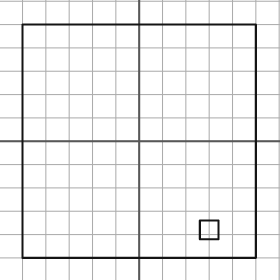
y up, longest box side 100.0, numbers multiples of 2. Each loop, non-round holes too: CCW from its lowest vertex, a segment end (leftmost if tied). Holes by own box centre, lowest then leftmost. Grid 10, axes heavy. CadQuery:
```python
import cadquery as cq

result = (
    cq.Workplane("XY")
    .moveTo(-50.0, -50.0)
    .lineTo(50.0, -50.0)
    .lineTo(50.0, 50.0)
    .lineTo(-50.0, 50.0)
    .close()
    .moveTo(26.0, -42.0)
    .lineTo(34.0, -42.0)
    .lineTo(34.0, -34.0)
    .lineTo(26.0, -34.0)
    .close()
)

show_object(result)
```